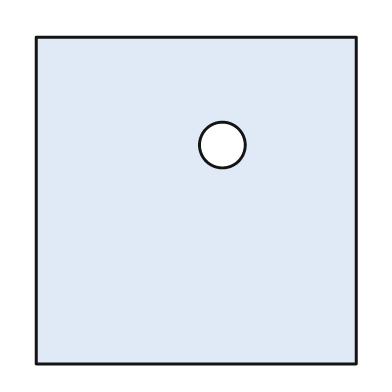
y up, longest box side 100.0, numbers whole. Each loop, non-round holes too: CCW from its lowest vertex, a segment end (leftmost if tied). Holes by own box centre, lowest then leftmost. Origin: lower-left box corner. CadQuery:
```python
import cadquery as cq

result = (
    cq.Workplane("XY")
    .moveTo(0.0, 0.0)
    .lineTo(98.0, 0.0)
    .lineTo(98.0, 100.0)
    .lineTo(0.0, 100.0)
    .close()
    .moveTo(57.0, 67.0)
    .circle(7.0)
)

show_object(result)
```